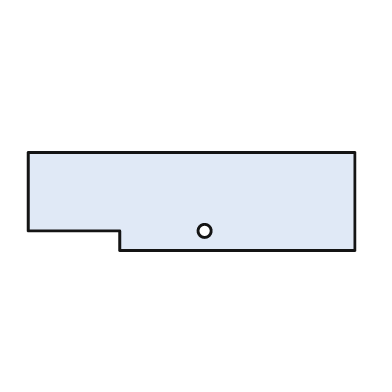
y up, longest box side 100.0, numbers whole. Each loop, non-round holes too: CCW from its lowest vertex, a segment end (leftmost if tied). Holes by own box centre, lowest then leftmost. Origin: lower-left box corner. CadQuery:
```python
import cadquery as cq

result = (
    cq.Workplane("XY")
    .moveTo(28.0, 0.0)
    .lineTo(100.0, 0.0)
    .lineTo(100.0, 30.0)
    .lineTo(0.0, 30.0)
    .lineTo(0.0, 6.0)
    .lineTo(28.0, 6.0)
    .close()
    .moveTo(54.0, 6.0)
    .circle(2.0)
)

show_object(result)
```